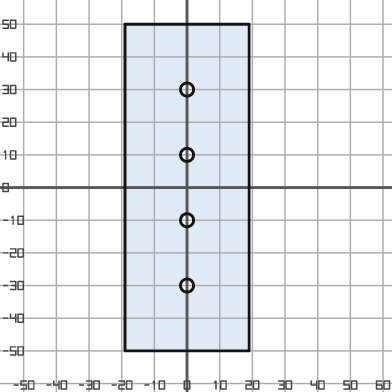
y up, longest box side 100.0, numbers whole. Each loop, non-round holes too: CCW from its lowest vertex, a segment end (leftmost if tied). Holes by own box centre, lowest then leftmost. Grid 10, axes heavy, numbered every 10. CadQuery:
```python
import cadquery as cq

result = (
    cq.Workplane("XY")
    .moveTo(-19.0, -50.0)
    .lineTo(19.0, -50.0)
    .lineTo(19.0, 50.0)
    .lineTo(-19.0, 50.0)
    .close()
    .moveTo(0.0, -30.0)
    .circle(2.0)
    .moveTo(0.0, -10.0)
    .circle(2.0)
    .moveTo(0.0, 10.0)
    .circle(2.0)
    .moveTo(0.0, 30.0)
    .circle(2.0)
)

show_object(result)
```